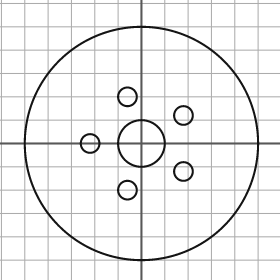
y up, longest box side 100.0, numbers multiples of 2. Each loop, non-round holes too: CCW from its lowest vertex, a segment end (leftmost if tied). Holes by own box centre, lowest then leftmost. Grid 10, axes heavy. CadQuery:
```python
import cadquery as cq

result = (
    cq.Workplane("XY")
    .moveTo(0.0, 0.0)
    .circle(50.0)
    .moveTo(-6.0, -20.0)
    .circle(4.0)
    .moveTo(18.0, -12.0)
    .circle(4.0)
    .moveTo(-22.0, 0.0)
    .circle(4.0)
    .moveTo(0.0, 0.0)
    .circle(10.0)
    .moveTo(18.0, 12.0)
    .circle(4.0)
    .moveTo(-6.0, 20.0)
    .circle(4.0)
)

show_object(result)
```